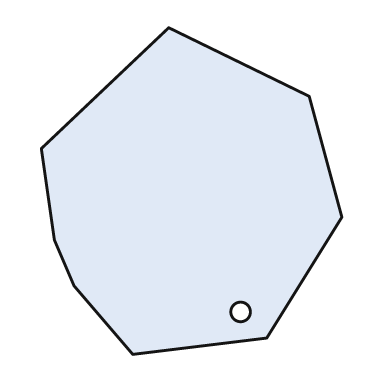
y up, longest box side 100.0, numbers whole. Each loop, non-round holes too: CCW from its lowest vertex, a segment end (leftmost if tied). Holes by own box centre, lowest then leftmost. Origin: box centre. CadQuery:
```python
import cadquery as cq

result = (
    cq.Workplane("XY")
    .moveTo(-18.0, -50.0)
    .lineTo(23.0, -45.0)
    .lineTo(46.0, -8.0)
    .lineTo(36.0, 29.0)
    .lineTo(-7.0, 50.0)
    .lineTo(-46.0, 13.0)
    .lineTo(-42.0, -15.0)
    .lineTo(-36.0, -29.0)
    .close()
    .moveTo(15.0, -37.0)
    .circle(3.0)
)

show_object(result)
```